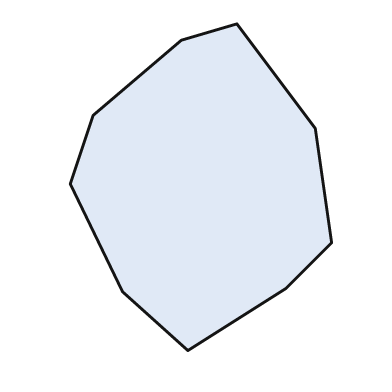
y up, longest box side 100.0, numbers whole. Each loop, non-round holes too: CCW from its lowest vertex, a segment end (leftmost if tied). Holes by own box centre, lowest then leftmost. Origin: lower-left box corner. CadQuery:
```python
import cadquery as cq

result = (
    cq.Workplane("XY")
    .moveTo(36.0, 0.0)
    .lineTo(66.0, 19.0)
    .lineTo(80.0, 33.0)
    .lineTo(75.0, 68.0)
    .lineTo(51.0, 100.0)
    .lineTo(34.0, 95.0)
    .lineTo(7.0, 72.0)
    .lineTo(0.0, 51.0)
    .lineTo(16.0, 18.0)
    .close()
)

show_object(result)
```